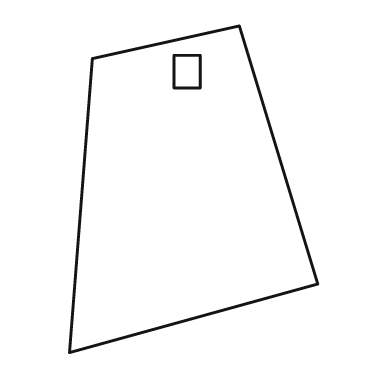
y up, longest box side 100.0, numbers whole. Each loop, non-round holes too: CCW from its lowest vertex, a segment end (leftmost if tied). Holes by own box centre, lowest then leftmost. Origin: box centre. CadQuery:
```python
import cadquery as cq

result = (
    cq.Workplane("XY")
    .moveTo(-38.0, -50.0)
    .lineTo(38.0, -29.0)
    .lineTo(14.0, 50.0)
    .lineTo(-31.0, 40.0)
    .close()
    .moveTo(-6.0, 31.0)
    .lineTo(2.0, 31.0)
    .lineTo(2.0, 41.0)
    .lineTo(-6.0, 41.0)
    .close()
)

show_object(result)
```